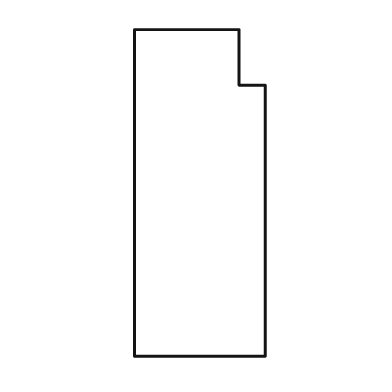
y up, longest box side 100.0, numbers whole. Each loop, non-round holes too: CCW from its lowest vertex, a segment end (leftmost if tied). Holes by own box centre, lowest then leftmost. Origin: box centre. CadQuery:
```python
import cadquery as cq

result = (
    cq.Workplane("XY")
    .moveTo(-20.0, -50.0)
    .lineTo(20.0, -50.0)
    .lineTo(20.0, 33.0)
    .lineTo(12.0, 33.0)
    .lineTo(12.0, 50.0)
    .lineTo(-20.0, 50.0)
    .close()
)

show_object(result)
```